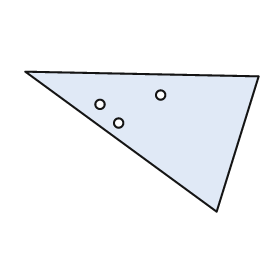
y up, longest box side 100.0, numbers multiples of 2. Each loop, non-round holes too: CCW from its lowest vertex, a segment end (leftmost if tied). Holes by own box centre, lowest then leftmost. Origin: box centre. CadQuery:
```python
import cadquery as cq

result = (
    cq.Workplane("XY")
    .moveTo(32.0, -30.0)
    .lineTo(50.0, 28.0)
    .lineTo(-50.0, 30.0)
    .close()
    .moveTo(-10.0, 8.0)
    .circle(2.0)
    .moveTo(-18.0, 16.0)
    .circle(2.0)
    .moveTo(8.0, 20.0)
    .circle(2.0)
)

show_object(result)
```